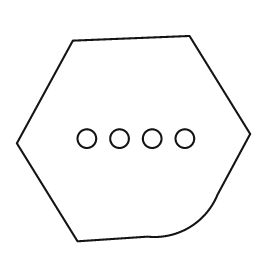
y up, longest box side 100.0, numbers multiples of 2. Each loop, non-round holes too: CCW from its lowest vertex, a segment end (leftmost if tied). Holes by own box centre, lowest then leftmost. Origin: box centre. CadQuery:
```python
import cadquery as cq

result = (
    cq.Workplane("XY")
    .moveTo(-24.0, -44.0)
    .lineTo(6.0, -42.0)
    .threePointArc((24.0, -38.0), (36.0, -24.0))
    .lineTo(50.0, 2.0)
    .lineTo(24.0, 44.0)
    .lineTo(-26.0, 42.0)
    .lineTo(-50.0, -2.0)
    .close()
    .moveTo(-20.0, 0.0)
    .circle(4.0)
    .moveTo(-6.0, 0.0)
    .circle(4.0)
    .moveTo(8.0, 0.0)
    .circle(4.0)
    .moveTo(22.0, 0.0)
    .circle(4.0)
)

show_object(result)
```